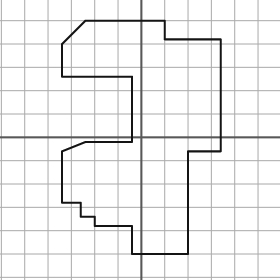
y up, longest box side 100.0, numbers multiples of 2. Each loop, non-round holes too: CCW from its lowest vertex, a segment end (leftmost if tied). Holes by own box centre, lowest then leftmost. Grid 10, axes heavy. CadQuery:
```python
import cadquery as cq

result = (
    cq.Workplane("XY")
    .moveTo(-4.0, -50.0)
    .lineTo(20.0, -50.0)
    .lineTo(20.0, -6.0)
    .lineTo(34.0, -6.0)
    .lineTo(34.0, 42.0)
    .lineTo(10.0, 42.0)
    .lineTo(10.0, 50.0)
    .lineTo(-24.0, 50.0)
    .lineTo(-34.0, 40.0)
    .lineTo(-34.0, 26.0)
    .lineTo(-4.0, 26.0)
    .lineTo(-4.0, -2.0)
    .lineTo(-24.0, -2.0)
    .lineTo(-34.0, -6.0)
    .lineTo(-34.0, -28.0)
    .lineTo(-26.0, -28.0)
    .lineTo(-26.0, -34.0)
    .lineTo(-20.0, -34.0)
    .lineTo(-20.0, -38.0)
    .lineTo(-4.0, -38.0)
    .close()
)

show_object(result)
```